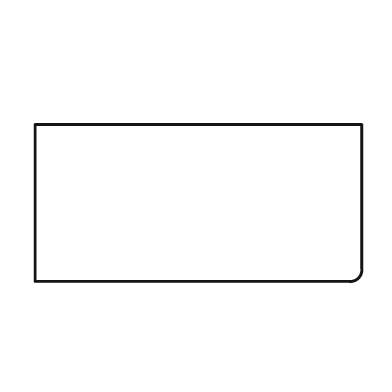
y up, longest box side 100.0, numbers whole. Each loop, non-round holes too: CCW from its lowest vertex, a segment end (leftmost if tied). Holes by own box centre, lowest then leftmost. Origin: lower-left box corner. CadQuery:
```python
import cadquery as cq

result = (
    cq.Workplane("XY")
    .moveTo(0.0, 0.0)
    .lineTo(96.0, 0.0)
    .threePointArc((99.0, 1.0), (100.0, 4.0))
    .lineTo(100.0, 48.0)
    .lineTo(0.0, 48.0)
    .close()
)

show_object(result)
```